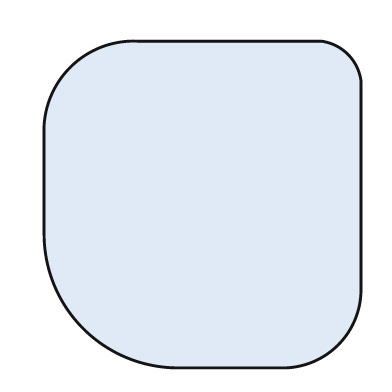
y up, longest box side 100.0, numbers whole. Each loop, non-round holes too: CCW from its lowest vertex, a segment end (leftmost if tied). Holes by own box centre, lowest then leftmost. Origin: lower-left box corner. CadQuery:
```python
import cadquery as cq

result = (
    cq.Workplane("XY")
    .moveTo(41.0, 0.0)
    .lineTo(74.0, 0.0)
    .threePointArc((90.0, 7.0), (97.0, 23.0))
    .lineTo(97.0, 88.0)
    .threePointArc((93.0, 96.0), (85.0, 100.0))
    .lineTo(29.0, 100.0)
    .threePointArc((8.0, 92.0), (0.0, 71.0))
    .lineTo(0.0, 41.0)
    .threePointArc((12.0, 12.0), (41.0, 0.0))
    .close()
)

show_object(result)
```